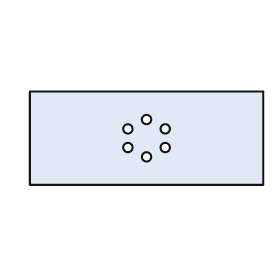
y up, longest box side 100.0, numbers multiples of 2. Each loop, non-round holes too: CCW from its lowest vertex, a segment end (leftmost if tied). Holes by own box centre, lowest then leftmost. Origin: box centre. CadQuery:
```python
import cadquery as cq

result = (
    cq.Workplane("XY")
    .moveTo(-50.0, -20.0)
    .lineTo(50.0, -20.0)
    .lineTo(50.0, 20.0)
    .lineTo(-50.0, 20.0)
    .close()
    .moveTo(0.0, -8.0)
    .circle(2.0)
    .moveTo(-8.0, -4.0)
    .circle(2.0)
    .moveTo(8.0, -4.0)
    .circle(2.0)
    .moveTo(-8.0, 4.0)
    .circle(2.0)
    .moveTo(8.0, 4.0)
    .circle(2.0)
    .moveTo(0.0, 8.0)
    .circle(2.0)
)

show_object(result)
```